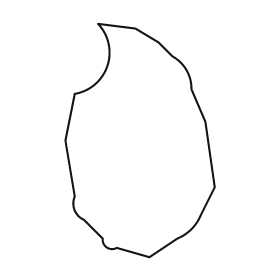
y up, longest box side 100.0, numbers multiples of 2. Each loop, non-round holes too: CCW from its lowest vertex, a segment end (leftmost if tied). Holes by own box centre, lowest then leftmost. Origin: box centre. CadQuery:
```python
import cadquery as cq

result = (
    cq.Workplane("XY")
    .moveTo(4.0, -50.0)
    .lineTo(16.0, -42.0)
    .threePointArc((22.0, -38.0), (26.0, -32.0))
    .lineTo(32.0, -20.0)
    .lineTo(28.0, 8.0)
    .lineTo(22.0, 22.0)
    .threePointArc((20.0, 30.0), (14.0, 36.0))
    .lineTo(8.0, 42.0)
    .lineTo(-2.0, 48.0)
    .lineTo(-18.0, 50.0)
    .threePointArc((-14.0, 32.0), (-28.0, 20.0))
    .lineTo(-32.0, 0.0)
    .lineTo(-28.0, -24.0)
    .threePointArc((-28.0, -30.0), (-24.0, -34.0))
    .lineTo(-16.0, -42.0)
    .threePointArc((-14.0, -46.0), (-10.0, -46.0))
    .close()
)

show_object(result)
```